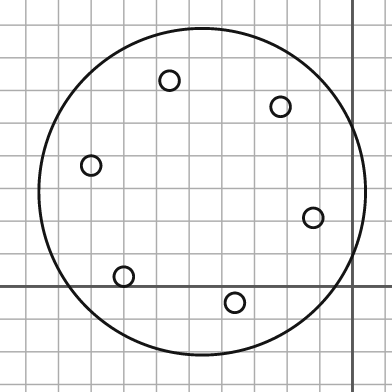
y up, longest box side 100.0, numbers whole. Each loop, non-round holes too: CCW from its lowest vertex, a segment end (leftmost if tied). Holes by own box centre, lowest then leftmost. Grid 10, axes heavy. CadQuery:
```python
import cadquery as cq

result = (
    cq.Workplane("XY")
    .moveTo(-46.0, 29.0)
    .circle(50.0)
    .moveTo(-36.0, -5.0)
    .circle(3.0)
    .moveTo(-70.0, 3.0)
    .circle(3.0)
    .moveTo(-12.0, 21.0)
    .circle(3.0)
    .moveTo(-80.0, 37.0)
    .circle(3.0)
    .moveTo(-22.0, 55.0)
    .circle(3.0)
    .moveTo(-56.0, 63.0)
    .circle(3.0)
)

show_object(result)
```